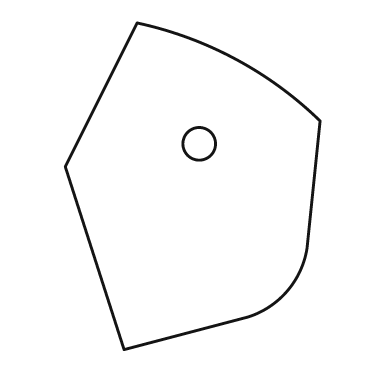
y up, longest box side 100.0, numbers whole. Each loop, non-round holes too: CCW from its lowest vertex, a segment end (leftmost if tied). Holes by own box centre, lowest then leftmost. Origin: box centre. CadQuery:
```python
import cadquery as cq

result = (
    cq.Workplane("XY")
    .moveTo(-21.0, -50.0)
    .lineTo(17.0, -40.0)
    .threePointArc((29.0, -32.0), (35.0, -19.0))
    .lineTo(39.0, 20.0)
    .threePointArc((13.0, 39.0), (-17.0, 50.0))
    .lineTo(-39.0, 6.0)
    .close()
    .moveTo(2.0, 13.0)
    .circle(5.0)
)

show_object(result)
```